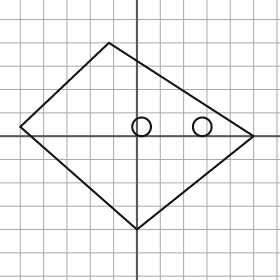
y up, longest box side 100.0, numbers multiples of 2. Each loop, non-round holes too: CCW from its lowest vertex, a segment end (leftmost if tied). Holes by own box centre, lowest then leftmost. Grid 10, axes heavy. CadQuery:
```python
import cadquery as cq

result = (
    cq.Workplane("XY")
    .moveTo(0.0, -40.0)
    .lineTo(50.0, 0.0)
    .lineTo(-12.0, 40.0)
    .lineTo(-50.0, 4.0)
    .close()
    .moveTo(2.0, 4.0)
    .circle(4.0)
    .moveTo(28.0, 4.0)
    .circle(4.0)
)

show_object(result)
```